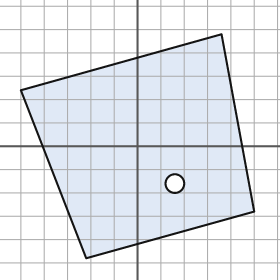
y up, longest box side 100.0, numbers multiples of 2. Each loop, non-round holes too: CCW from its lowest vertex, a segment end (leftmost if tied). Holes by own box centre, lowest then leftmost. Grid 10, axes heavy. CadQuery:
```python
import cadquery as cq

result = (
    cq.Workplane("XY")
    .moveTo(-22.0, -48.0)
    .lineTo(50.0, -28.0)
    .lineTo(36.0, 48.0)
    .lineTo(-50.0, 24.0)
    .close()
    .moveTo(16.0, -16.0)
    .circle(4.0)
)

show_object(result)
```